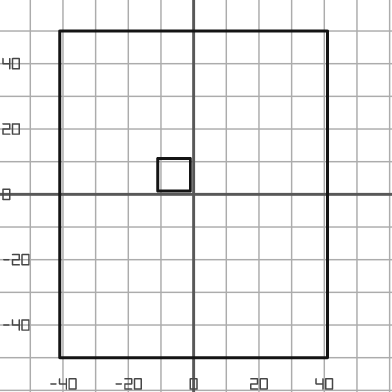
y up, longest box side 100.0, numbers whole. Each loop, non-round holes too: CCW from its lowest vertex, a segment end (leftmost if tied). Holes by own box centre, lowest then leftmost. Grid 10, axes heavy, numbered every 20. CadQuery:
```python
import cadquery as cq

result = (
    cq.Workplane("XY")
    .moveTo(-41.0, -50.0)
    .lineTo(41.0, -50.0)
    .lineTo(41.0, 50.0)
    .lineTo(-41.0, 50.0)
    .close()
    .moveTo(-11.0, 1.0)
    .lineTo(-1.0, 1.0)
    .lineTo(-1.0, 11.0)
    .lineTo(-11.0, 11.0)
    .close()
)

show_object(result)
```